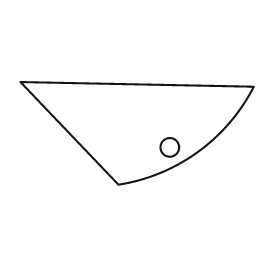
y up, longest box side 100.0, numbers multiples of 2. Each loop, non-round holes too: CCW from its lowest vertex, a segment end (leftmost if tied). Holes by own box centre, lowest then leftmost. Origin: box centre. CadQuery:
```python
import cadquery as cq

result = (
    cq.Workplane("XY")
    .moveTo(-8.0, -22.0)
    .threePointArc((26.0, -8.0), (50.0, 20.0))
    .lineTo(-50.0, 22.0)
    .close()
    .moveTo(14.0, -6.0)
    .circle(4.0)
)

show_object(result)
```